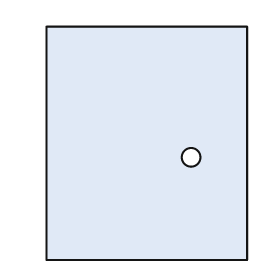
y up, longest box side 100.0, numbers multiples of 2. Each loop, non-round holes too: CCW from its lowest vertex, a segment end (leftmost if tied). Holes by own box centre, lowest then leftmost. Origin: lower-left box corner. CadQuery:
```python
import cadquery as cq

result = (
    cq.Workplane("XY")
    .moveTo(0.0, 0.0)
    .lineTo(86.0, 0.0)
    .lineTo(86.0, 100.0)
    .lineTo(0.0, 100.0)
    .close()
    .moveTo(62.0, 44.0)
    .circle(4.0)
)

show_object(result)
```